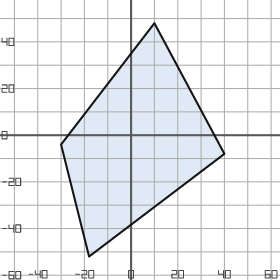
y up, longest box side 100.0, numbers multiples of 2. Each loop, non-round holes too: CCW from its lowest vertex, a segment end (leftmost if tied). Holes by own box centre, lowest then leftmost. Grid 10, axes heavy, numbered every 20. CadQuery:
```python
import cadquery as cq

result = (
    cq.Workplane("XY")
    .moveTo(-18.0, -52.0)
    .lineTo(40.0, -8.0)
    .lineTo(10.0, 48.0)
    .lineTo(-30.0, -4.0)
    .close()
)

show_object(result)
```